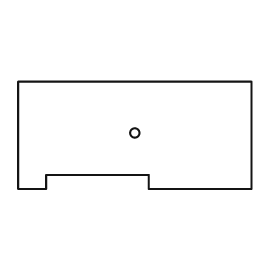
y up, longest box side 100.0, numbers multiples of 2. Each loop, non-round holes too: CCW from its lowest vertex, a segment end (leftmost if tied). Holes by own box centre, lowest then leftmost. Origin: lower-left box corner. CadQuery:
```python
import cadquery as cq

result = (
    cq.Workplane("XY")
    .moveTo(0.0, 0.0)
    .lineTo(12.0, 0.0)
    .lineTo(12.0, 6.0)
    .lineTo(56.0, 6.0)
    .lineTo(56.0, 0.0)
    .lineTo(100.0, 0.0)
    .lineTo(100.0, 46.0)
    .lineTo(0.0, 46.0)
    .close()
    .moveTo(50.0, 24.0)
    .circle(2.0)
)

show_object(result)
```